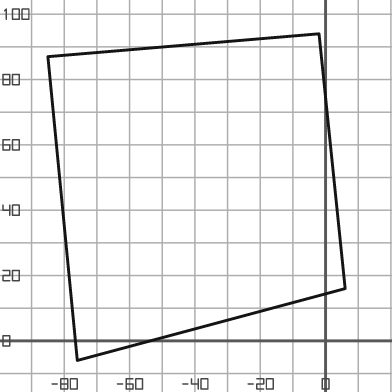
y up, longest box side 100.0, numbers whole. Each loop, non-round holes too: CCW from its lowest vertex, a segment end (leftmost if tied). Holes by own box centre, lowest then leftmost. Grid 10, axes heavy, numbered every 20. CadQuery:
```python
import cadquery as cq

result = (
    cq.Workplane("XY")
    .moveTo(-76.0, -6.0)
    .lineTo(6.0, 16.0)
    .lineTo(-2.0, 94.0)
    .lineTo(-85.0, 87.0)
    .close()
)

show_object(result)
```